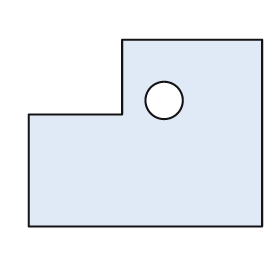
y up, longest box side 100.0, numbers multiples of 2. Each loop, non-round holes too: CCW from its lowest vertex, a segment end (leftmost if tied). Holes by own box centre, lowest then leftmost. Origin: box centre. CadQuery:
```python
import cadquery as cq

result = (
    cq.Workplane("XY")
    .moveTo(-50.0, -40.0)
    .lineTo(50.0, -40.0)
    .lineTo(50.0, 40.0)
    .lineTo(-10.0, 40.0)
    .lineTo(-10.0, 8.0)
    .lineTo(-50.0, 8.0)
    .close()
    .moveTo(8.0, 14.0)
    .circle(8.0)
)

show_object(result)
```